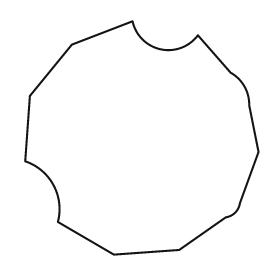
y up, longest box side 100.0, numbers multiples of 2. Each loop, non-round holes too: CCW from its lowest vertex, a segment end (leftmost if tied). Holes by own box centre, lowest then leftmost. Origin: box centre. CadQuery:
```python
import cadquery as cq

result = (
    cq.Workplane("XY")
    .moveTo(-12.0, -50.0)
    .lineTo(16.0, -48.0)
    .lineTo(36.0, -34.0)
    .threePointArc((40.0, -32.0), (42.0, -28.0))
    .lineTo(50.0, -6.0)
    .lineTo(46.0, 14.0)
    .threePointArc((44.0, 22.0), (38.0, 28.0))
    .lineTo(24.0, 44.0)
    .threePointArc((8.0, 38.0), (-4.0, 50.0))
    .lineTo(-30.0, 40.0)
    .lineTo(-48.0, 18.0)
    .lineTo(-50.0, -10.0)
    .threePointArc((-38.0, -20.0), (-36.0, -36.0))
    .close()
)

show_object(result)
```